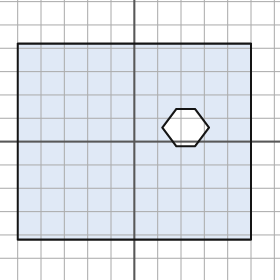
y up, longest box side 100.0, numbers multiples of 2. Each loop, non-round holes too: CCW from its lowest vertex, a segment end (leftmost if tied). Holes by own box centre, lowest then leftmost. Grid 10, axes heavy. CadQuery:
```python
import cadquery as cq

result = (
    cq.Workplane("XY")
    .moveTo(-50.0, -42.0)
    .lineTo(50.0, -42.0)
    .lineTo(50.0, 42.0)
    .lineTo(-50.0, 42.0)
    .close()
    .moveTo(18.0, -2.0)
    .lineTo(26.0, -2.0)
    .lineTo(32.0, 6.0)
    .lineTo(26.0, 14.0)
    .lineTo(18.0, 14.0)
    .lineTo(12.0, 6.0)
    .close()
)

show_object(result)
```